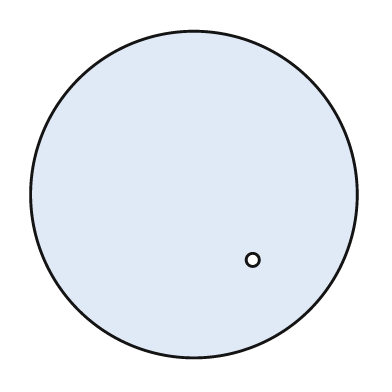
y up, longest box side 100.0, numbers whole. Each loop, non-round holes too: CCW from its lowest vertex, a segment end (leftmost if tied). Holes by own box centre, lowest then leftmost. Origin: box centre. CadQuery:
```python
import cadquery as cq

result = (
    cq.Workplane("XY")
    .moveTo(0.0, 0.0)
    .circle(50.0)
    .moveTo(18.0, -20.0)
    .circle(2.0)
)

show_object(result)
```